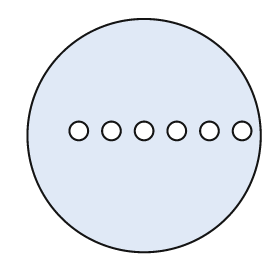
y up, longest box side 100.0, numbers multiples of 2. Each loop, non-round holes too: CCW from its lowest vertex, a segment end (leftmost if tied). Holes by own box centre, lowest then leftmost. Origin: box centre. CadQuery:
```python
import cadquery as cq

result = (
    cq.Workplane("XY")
    .moveTo(0.0, 0.0)
    .circle(50.0)
    .moveTo(-28.0, 2.0)
    .circle(4.0)
    .moveTo(-14.0, 2.0)
    .circle(4.0)
    .moveTo(0.0, 2.0)
    .circle(4.0)
    .moveTo(14.0, 2.0)
    .circle(4.0)
    .moveTo(28.0, 2.0)
    .circle(4.0)
    .moveTo(42.0, 2.0)
    .circle(4.0)
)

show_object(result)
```